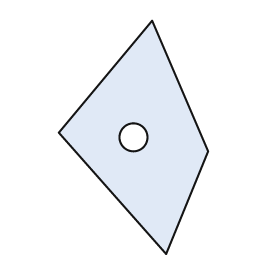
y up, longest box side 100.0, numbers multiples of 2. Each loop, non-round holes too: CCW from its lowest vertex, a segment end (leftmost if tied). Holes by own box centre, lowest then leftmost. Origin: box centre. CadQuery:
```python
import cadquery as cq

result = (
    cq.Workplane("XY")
    .moveTo(14.0, -50.0)
    .lineTo(32.0, -6.0)
    .lineTo(8.0, 50.0)
    .lineTo(-32.0, 2.0)
    .close()
    .moveTo(0.0, 0.0)
    .circle(6.0)
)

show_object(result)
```